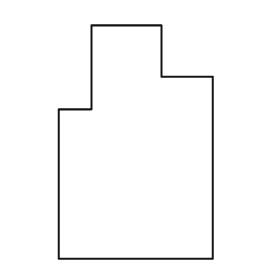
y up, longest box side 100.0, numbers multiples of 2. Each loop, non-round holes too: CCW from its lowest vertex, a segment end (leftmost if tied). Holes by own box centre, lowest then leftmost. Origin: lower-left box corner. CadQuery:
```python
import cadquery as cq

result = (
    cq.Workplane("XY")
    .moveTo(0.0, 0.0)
    .lineTo(66.0, 0.0)
    .lineTo(66.0, 78.0)
    .lineTo(44.0, 78.0)
    .lineTo(44.0, 100.0)
    .lineTo(14.0, 100.0)
    .lineTo(14.0, 64.0)
    .lineTo(0.0, 64.0)
    .close()
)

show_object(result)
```